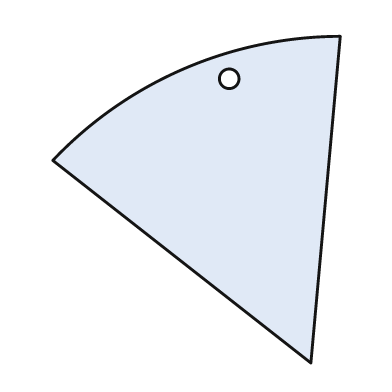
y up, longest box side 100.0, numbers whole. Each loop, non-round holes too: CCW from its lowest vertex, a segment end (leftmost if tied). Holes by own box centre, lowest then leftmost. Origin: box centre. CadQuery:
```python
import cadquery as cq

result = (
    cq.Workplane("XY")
    .moveTo(35.0, -50.0)
    .lineTo(44.0, 50.0)
    .threePointArc((-4.0, 40.0), (-44.0, 12.0))
    .close()
    .moveTo(10.0, 37.0)
    .circle(3.0)
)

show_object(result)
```